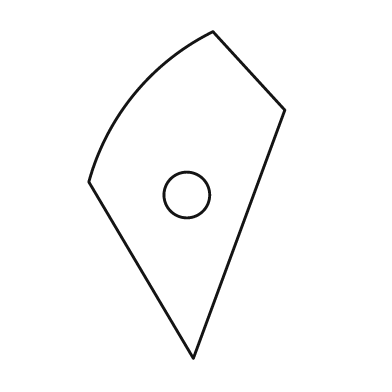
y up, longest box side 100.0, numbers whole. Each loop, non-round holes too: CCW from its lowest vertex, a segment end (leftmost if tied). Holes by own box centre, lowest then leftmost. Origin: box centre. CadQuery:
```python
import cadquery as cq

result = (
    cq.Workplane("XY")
    .moveTo(2.0, -50.0)
    .lineTo(30.0, 26.0)
    .lineTo(8.0, 50.0)
    .threePointArc((-16.0, 31.0), (-30.0, 4.0))
    .close()
    .moveTo(0.0, 0.0)
    .circle(7.0)
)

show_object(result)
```